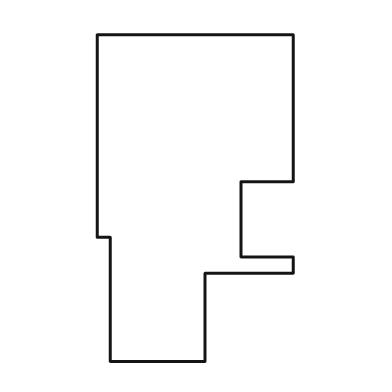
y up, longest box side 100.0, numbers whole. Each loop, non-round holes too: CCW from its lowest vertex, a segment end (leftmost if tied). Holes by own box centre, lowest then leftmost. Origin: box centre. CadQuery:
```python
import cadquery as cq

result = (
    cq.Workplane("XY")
    .moveTo(-26.0, -50.0)
    .lineTo(3.0, -50.0)
    .lineTo(3.0, -23.0)
    .lineTo(30.0, -23.0)
    .lineTo(30.0, -18.0)
    .lineTo(14.0, -18.0)
    .lineTo(14.0, 5.0)
    .lineTo(30.0, 5.0)
    .lineTo(30.0, 50.0)
    .lineTo(-30.0, 50.0)
    .lineTo(-30.0, -12.0)
    .lineTo(-26.0, -12.0)
    .close()
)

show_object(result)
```